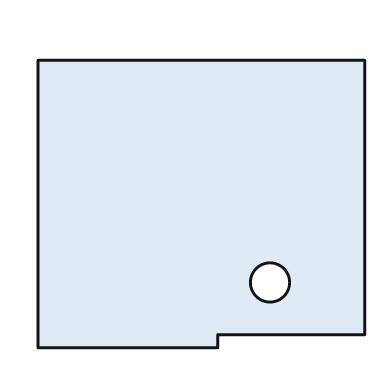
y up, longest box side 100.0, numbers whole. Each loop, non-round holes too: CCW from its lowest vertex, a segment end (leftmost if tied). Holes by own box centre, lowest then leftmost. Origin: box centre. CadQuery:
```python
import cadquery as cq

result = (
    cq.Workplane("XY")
    .moveTo(-50.0, -44.0)
    .lineTo(5.0, -44.0)
    .lineTo(5.0, -40.0)
    .lineTo(50.0, -40.0)
    .lineTo(50.0, 44.0)
    .lineTo(-50.0, 44.0)
    .close()
    .moveTo(21.0, -24.0)
    .circle(6.0)
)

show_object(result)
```